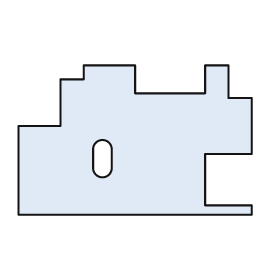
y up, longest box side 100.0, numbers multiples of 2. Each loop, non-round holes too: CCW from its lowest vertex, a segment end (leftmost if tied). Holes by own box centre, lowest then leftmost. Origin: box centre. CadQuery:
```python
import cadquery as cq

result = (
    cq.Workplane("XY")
    .moveTo(-50.0, -32.0)
    .lineTo(50.0, -32.0)
    .lineTo(50.0, -28.0)
    .lineTo(30.0, -28.0)
    .lineTo(30.0, -6.0)
    .lineTo(50.0, -6.0)
    .lineTo(50.0, 18.0)
    .lineTo(40.0, 18.0)
    .lineTo(40.0, 32.0)
    .lineTo(30.0, 32.0)
    .lineTo(30.0, 20.0)
    .lineTo(0.0, 20.0)
    .lineTo(0.0, 32.0)
    .lineTo(-22.0, 32.0)
    .lineTo(-22.0, 26.0)
    .lineTo(-32.0, 26.0)
    .lineTo(-32.0, 6.0)
    .lineTo(-50.0, 6.0)
    .close()
    .moveTo(-18.0, -12.0)
    .threePointArc((-14.0, -16.0), (-10.0, -12.0))
    .lineTo(-10.0, -4.0)
    .threePointArc((-14.0, 0.0), (-18.0, -4.0))
    .close()
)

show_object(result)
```